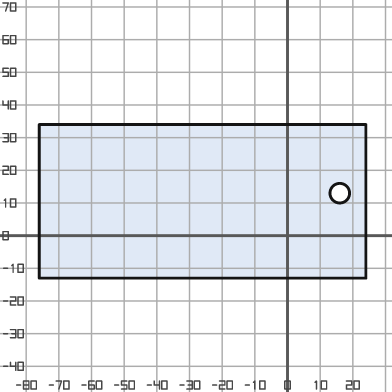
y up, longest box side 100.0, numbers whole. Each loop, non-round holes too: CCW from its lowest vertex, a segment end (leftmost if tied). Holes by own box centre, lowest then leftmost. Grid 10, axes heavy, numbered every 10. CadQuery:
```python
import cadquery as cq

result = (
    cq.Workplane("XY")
    .moveTo(-76.0, -13.0)
    .lineTo(24.0, -13.0)
    .lineTo(24.0, 34.0)
    .lineTo(-76.0, 34.0)
    .close()
    .moveTo(16.0, 13.0)
    .circle(3.0)
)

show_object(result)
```